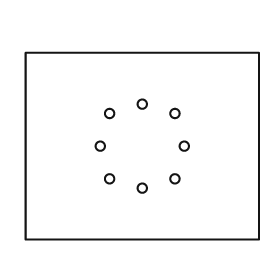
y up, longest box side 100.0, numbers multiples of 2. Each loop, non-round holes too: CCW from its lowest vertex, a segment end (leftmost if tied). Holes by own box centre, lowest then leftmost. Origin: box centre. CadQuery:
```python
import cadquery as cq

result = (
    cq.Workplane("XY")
    .moveTo(-50.0, -40.0)
    .lineTo(50.0, -40.0)
    .lineTo(50.0, 40.0)
    .lineTo(-50.0, 40.0)
    .close()
    .moveTo(0.0, -18.0)
    .circle(2.0)
    .moveTo(-14.0, -14.0)
    .circle(2.0)
    .moveTo(14.0, -14.0)
    .circle(2.0)
    .moveTo(-18.0, 0.0)
    .circle(2.0)
    .moveTo(18.0, 0.0)
    .circle(2.0)
    .moveTo(-14.0, 14.0)
    .circle(2.0)
    .moveTo(14.0, 14.0)
    .circle(2.0)
    .moveTo(0.0, 18.0)
    .circle(2.0)
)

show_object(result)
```